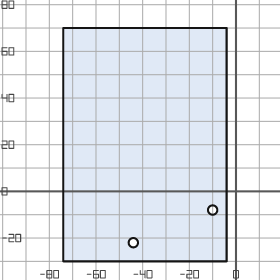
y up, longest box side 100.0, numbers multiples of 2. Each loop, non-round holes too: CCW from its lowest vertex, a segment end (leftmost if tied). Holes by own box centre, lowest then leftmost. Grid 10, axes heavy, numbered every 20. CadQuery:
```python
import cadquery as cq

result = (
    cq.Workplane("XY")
    .moveTo(-74.0, -30.0)
    .lineTo(-4.0, -30.0)
    .lineTo(-4.0, 70.0)
    .lineTo(-74.0, 70.0)
    .close()
    .moveTo(-44.0, -22.0)
    .circle(2.0)
    .moveTo(-10.0, -8.0)
    .circle(2.0)
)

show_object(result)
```